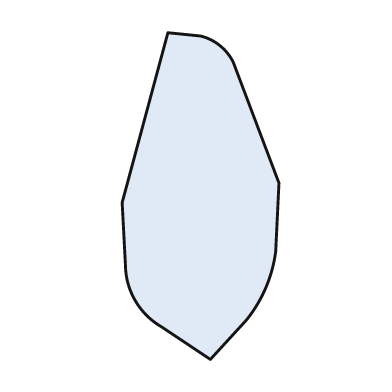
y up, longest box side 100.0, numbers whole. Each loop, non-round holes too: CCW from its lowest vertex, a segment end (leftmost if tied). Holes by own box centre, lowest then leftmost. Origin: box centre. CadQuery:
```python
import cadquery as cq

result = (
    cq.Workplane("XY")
    .moveTo(3.0, -50.0)
    .lineTo(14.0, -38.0)
    .threePointArc((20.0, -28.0), (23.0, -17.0))
    .lineTo(24.0, 4.0)
    .lineTo(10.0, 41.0)
    .threePointArc((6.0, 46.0), (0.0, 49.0))
    .lineTo(-10.0, 50.0)
    .lineTo(-24.0, -2.0)
    .lineTo(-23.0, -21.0)
    .threePointArc((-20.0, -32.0), (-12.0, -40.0))
    .close()
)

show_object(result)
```